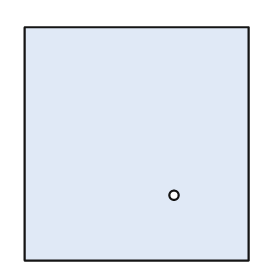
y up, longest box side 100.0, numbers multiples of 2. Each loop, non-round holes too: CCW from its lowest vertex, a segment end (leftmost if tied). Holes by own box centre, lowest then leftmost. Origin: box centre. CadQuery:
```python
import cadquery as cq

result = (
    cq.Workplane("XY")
    .moveTo(-48.0, -50.0)
    .lineTo(48.0, -50.0)
    .lineTo(48.0, 50.0)
    .lineTo(-48.0, 50.0)
    .close()
    .moveTo(16.0, -22.0)
    .circle(2.0)
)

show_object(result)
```